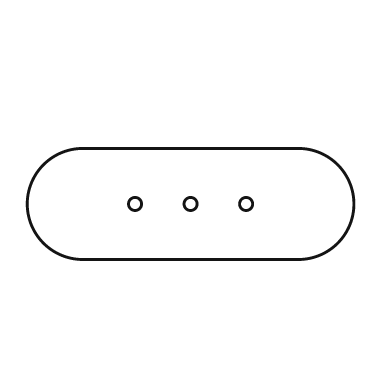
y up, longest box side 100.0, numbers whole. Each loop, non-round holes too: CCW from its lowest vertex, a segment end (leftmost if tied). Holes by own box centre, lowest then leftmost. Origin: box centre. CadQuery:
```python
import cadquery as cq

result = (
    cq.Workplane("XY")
    .moveTo(-33.0, -17.0)
    .lineTo(33.0, -17.0)
    .threePointArc((50.0, 0.0), (33.0, 17.0))
    .lineTo(-33.0, 17.0)
    .threePointArc((-50.0, 0.0), (-33.0, -17.0))
    .close()
    .moveTo(-17.0, 0.0)
    .circle(2.0)
    .moveTo(0.0, 0.0)
    .circle(2.0)
    .moveTo(17.0, 0.0)
    .circle(2.0)
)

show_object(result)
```